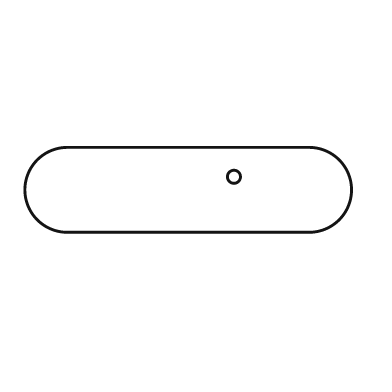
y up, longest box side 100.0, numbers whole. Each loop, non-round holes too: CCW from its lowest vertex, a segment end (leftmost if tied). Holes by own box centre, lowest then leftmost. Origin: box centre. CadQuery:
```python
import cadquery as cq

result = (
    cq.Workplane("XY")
    .moveTo(-37.0, -13.0)
    .lineTo(37.0, -13.0)
    .threePointArc((50.0, 0.0), (37.0, 13.0))
    .lineTo(-37.0, 13.0)
    .threePointArc((-50.0, 0.0), (-37.0, -13.0))
    .close()
    .moveTo(14.0, 4.0)
    .circle(2.0)
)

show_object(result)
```